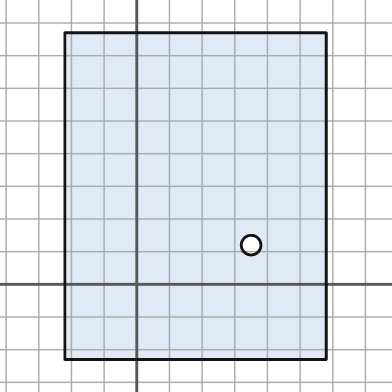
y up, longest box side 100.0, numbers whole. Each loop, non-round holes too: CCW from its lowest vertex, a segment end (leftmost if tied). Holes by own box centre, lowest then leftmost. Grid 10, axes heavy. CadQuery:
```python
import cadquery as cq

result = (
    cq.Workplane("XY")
    .moveTo(-22.0, -23.0)
    .lineTo(58.0, -23.0)
    .lineTo(58.0, 77.0)
    .lineTo(-22.0, 77.0)
    .close()
    .moveTo(35.0, 12.0)
    .circle(3.0)
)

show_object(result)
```